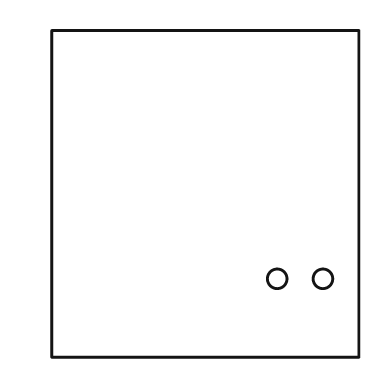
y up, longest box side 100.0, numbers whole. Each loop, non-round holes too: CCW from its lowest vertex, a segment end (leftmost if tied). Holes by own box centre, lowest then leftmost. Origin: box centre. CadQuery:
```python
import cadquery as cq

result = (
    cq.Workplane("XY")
    .moveTo(-47.0, -50.0)
    .lineTo(47.0, -50.0)
    .lineTo(47.0, 50.0)
    .lineTo(-47.0, 50.0)
    .close()
    .moveTo(22.0, -26.0)
    .circle(3.0)
    .moveTo(36.0, -26.0)
    .circle(3.0)
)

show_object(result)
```